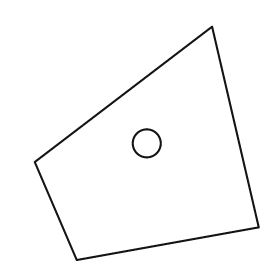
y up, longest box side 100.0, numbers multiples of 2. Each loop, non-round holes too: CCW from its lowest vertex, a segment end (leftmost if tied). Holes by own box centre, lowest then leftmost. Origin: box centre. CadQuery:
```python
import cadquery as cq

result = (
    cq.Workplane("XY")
    .moveTo(-30.0, -50.0)
    .lineTo(48.0, -36.0)
    .lineTo(28.0, 50.0)
    .lineTo(-48.0, -8.0)
    .close()
    .moveTo(0.0, 0.0)
    .circle(6.0)
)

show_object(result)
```